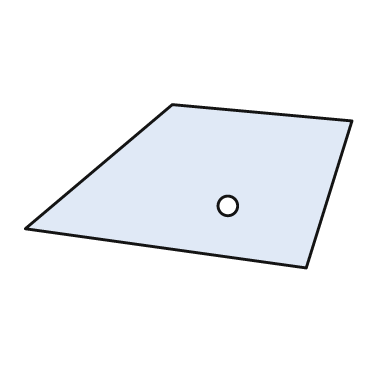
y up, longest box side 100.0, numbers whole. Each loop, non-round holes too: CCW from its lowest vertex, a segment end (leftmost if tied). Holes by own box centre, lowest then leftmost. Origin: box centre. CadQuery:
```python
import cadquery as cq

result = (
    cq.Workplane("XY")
    .moveTo(36.0, -25.0)
    .lineTo(50.0, 20.0)
    .lineTo(-5.0, 25.0)
    .lineTo(-50.0, -13.0)
    .close()
    .moveTo(12.0, -6.0)
    .circle(3.0)
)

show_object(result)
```